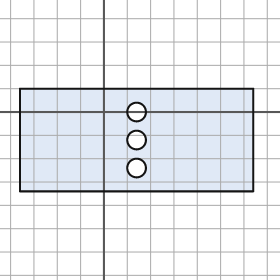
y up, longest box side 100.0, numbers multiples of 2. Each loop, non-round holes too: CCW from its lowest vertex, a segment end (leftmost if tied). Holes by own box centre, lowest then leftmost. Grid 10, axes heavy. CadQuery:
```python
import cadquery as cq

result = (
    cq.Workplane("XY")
    .moveTo(-36.0, -34.0)
    .lineTo(64.0, -34.0)
    .lineTo(64.0, 10.0)
    .lineTo(-36.0, 10.0)
    .close()
    .moveTo(14.0, -24.0)
    .circle(4.0)
    .moveTo(14.0, -12.0)
    .circle(4.0)
    .moveTo(14.0, 0.0)
    .circle(4.0)
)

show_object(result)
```